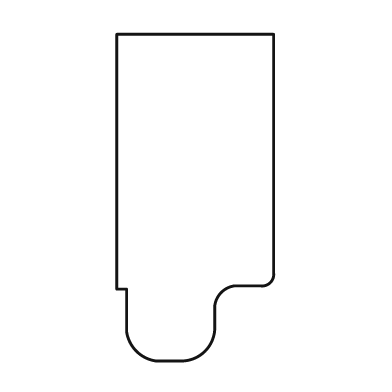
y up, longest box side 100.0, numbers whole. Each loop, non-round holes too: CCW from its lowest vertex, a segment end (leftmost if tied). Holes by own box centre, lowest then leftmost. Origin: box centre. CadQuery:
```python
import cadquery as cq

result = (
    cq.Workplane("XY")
    .moveTo(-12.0, -50.0)
    .lineTo(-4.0, -50.0)
    .threePointArc((3.0, -47.0), (6.0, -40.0))
    .lineTo(6.0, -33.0)
    .threePointArc((8.0, -29.0), (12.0, -27.0))
    .lineTo(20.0, -27.0)
    .threePointArc((23.0, -26.0), (24.0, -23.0))
    .lineTo(24.0, 50.0)
    .lineTo(-24.0, 50.0)
    .lineTo(-24.0, -28.0)
    .lineTo(-21.0, -28.0)
    .lineTo(-21.0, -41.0)
    .threePointArc((-18.0, -47.0), (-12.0, -50.0))
    .close()
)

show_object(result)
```